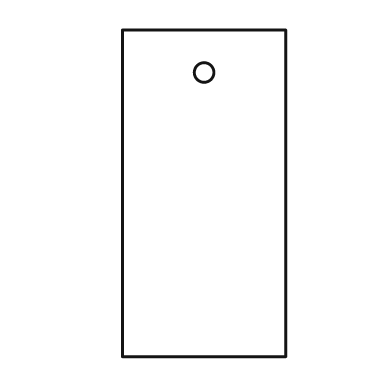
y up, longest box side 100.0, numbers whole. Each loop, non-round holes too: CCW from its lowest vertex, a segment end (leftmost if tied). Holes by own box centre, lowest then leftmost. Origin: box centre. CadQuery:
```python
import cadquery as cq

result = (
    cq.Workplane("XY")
    .moveTo(-25.0, -50.0)
    .lineTo(25.0, -50.0)
    .lineTo(25.0, 50.0)
    .lineTo(-25.0, 50.0)
    .close()
    .moveTo(0.0, 37.0)
    .circle(3.0)
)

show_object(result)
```